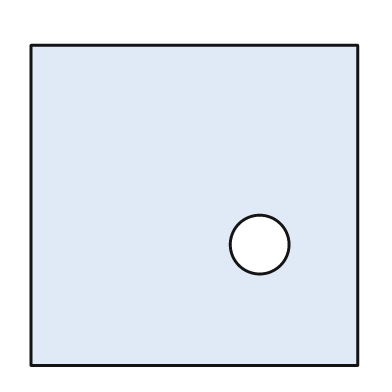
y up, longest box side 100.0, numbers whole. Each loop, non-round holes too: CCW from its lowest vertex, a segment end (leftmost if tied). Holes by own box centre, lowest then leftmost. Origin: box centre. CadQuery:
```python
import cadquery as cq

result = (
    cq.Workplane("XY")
    .moveTo(-50.0, -49.0)
    .lineTo(50.0, -49.0)
    .lineTo(50.0, 49.0)
    .lineTo(-50.0, 49.0)
    .close()
    .moveTo(20.0, -12.0)
    .circle(9.0)
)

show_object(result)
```